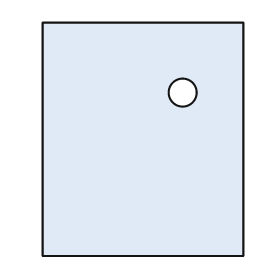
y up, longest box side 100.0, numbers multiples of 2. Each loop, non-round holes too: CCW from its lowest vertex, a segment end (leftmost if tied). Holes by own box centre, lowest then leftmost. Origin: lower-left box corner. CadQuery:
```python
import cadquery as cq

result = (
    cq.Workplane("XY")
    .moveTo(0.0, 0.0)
    .lineTo(86.0, 0.0)
    .lineTo(86.0, 100.0)
    .lineTo(0.0, 100.0)
    .close()
    .moveTo(60.0, 70.0)
    .circle(6.0)
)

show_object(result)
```